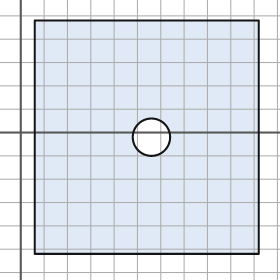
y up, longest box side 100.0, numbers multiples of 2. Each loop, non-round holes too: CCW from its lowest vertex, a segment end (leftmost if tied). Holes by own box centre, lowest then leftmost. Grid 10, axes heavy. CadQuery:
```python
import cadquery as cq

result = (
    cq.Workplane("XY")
    .moveTo(6.0, -52.0)
    .lineTo(102.0, -52.0)
    .lineTo(102.0, 48.0)
    .lineTo(6.0, 48.0)
    .close()
    .moveTo(56.0, -2.0)
    .circle(8.0)
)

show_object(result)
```